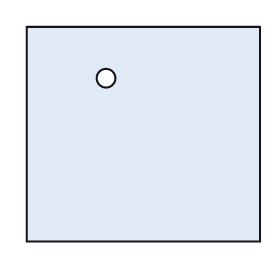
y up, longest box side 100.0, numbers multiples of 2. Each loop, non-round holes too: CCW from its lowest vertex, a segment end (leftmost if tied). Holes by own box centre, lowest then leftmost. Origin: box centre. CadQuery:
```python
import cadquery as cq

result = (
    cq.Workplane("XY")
    .moveTo(-50.0, -46.0)
    .lineTo(50.0, -46.0)
    .lineTo(50.0, 46.0)
    .lineTo(-50.0, 46.0)
    .close()
    .moveTo(-16.0, 24.0)
    .circle(4.0)
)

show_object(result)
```